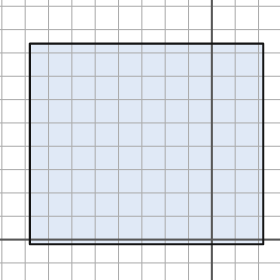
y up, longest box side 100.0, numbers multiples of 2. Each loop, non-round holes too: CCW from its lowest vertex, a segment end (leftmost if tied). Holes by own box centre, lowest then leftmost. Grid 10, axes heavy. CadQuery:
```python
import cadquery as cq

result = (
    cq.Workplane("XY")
    .moveTo(-78.0, -2.0)
    .lineTo(22.0, -2.0)
    .lineTo(22.0, 84.0)
    .lineTo(-78.0, 84.0)
    .close()
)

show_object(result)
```